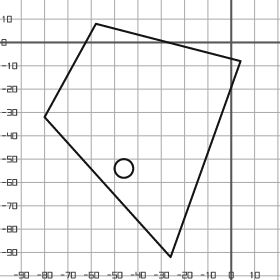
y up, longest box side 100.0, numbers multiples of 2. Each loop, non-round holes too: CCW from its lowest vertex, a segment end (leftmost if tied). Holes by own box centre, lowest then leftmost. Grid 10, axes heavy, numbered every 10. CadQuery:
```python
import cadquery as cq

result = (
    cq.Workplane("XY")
    .moveTo(-26.0, -92.0)
    .lineTo(4.0, -8.0)
    .lineTo(-58.0, 8.0)
    .lineTo(-80.0, -32.0)
    .close()
    .moveTo(-46.0, -54.0)
    .circle(4.0)
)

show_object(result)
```